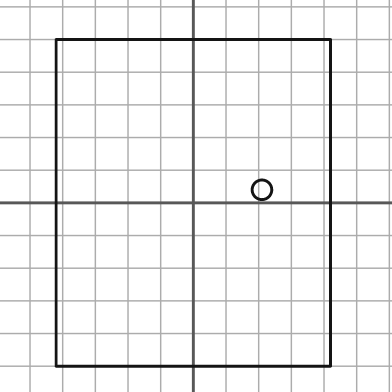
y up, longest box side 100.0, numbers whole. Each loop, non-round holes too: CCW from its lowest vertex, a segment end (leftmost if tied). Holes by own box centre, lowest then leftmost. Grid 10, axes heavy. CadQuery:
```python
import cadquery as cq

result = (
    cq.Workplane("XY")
    .moveTo(-42.0, -50.0)
    .lineTo(42.0, -50.0)
    .lineTo(42.0, 50.0)
    .lineTo(-42.0, 50.0)
    .close()
    .moveTo(21.0, 4.0)
    .circle(3.0)
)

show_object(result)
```